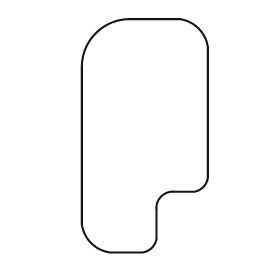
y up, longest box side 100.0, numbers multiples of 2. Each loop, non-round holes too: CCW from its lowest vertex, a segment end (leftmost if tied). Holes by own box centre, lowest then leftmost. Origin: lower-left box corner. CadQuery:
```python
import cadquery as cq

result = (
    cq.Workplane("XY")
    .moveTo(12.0, 0.0)
    .lineTo(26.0, 0.0)
    .threePointArc((30.0, 2.0), (32.0, 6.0))
    .lineTo(32.0, 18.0)
    .threePointArc((34.0, 24.0), (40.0, 26.0))
    .lineTo(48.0, 26.0)
    .threePointArc((52.0, 28.0), (54.0, 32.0))
    .lineTo(54.0, 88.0)
    .threePointArc((50.0, 96.0), (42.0, 100.0))
    .lineTo(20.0, 100.0)
    .threePointArc((6.0, 94.0), (0.0, 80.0))
    .lineTo(0.0, 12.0)
    .threePointArc((4.0, 4.0), (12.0, 0.0))
    .close()
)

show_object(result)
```